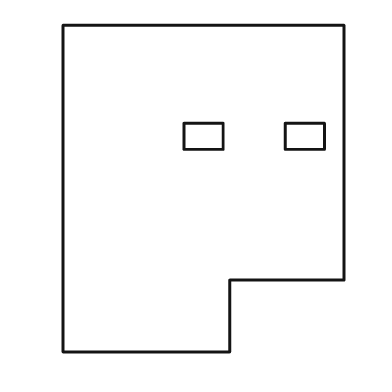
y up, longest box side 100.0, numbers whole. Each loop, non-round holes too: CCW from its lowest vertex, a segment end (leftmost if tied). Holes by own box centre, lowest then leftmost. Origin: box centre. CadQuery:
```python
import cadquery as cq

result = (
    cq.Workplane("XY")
    .moveTo(-43.0, -50.0)
    .lineTo(8.0, -50.0)
    .lineTo(8.0, -28.0)
    .lineTo(43.0, -28.0)
    .lineTo(43.0, 50.0)
    .lineTo(-43.0, 50.0)
    .close()
    .moveTo(-6.0, 12.0)
    .lineTo(6.0, 12.0)
    .lineTo(6.0, 20.0)
    .lineTo(-6.0, 20.0)
    .close()
    .moveTo(25.0, 12.0)
    .lineTo(37.0, 12.0)
    .lineTo(37.0, 20.0)
    .lineTo(25.0, 20.0)
    .close()
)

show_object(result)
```